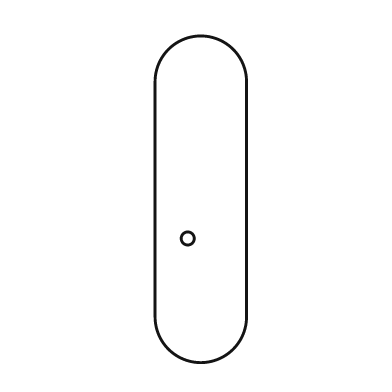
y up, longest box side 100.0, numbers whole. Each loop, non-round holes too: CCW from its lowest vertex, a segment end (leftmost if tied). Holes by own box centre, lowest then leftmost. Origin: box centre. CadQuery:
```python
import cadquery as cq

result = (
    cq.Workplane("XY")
    .moveTo(-14.0, -36.0)
    .threePointArc((0.0, -50.0), (14.0, -36.0))
    .lineTo(14.0, 36.0)
    .threePointArc((0.0, 50.0), (-14.0, 36.0))
    .close()
    .moveTo(-4.0, -12.0)
    .circle(2.0)
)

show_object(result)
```